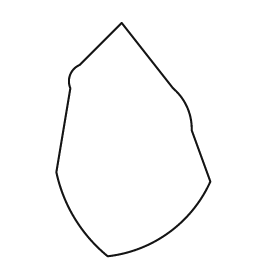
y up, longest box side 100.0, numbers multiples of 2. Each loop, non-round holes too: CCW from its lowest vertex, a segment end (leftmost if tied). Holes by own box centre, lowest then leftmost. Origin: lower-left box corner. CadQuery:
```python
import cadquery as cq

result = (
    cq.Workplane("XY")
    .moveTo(22.0, 0.0)
    .threePointArc((48.0, 10.0), (66.0, 32.0))
    .lineTo(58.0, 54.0)
    .threePointArc((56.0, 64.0), (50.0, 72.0))
    .lineTo(28.0, 100.0)
    .lineTo(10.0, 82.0)
    .threePointArc((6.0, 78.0), (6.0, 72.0))
    .lineTo(0.0, 36.0)
    .threePointArc((8.0, 16.0), (22.0, 0.0))
    .close()
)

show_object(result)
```